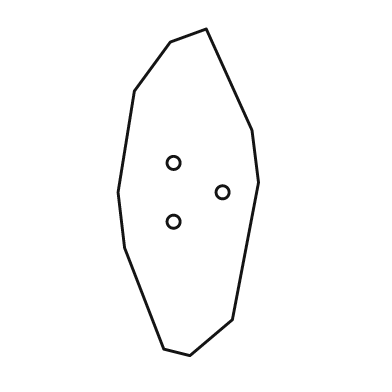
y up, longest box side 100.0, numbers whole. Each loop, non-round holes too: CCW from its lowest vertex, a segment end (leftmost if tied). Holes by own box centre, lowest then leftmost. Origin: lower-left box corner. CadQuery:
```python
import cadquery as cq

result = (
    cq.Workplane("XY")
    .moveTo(22.0, 0.0)
    .lineTo(35.0, 11.0)
    .lineTo(43.0, 53.0)
    .lineTo(41.0, 69.0)
    .lineTo(27.0, 100.0)
    .lineTo(16.0, 96.0)
    .lineTo(5.0, 81.0)
    .lineTo(0.0, 50.0)
    .lineTo(2.0, 33.0)
    .lineTo(14.0, 2.0)
    .close()
    .moveTo(17.0, 41.0)
    .circle(2.0)
    .moveTo(32.0, 50.0)
    .circle(2.0)
    .moveTo(17.0, 59.0)
    .circle(2.0)
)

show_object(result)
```